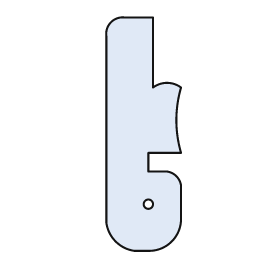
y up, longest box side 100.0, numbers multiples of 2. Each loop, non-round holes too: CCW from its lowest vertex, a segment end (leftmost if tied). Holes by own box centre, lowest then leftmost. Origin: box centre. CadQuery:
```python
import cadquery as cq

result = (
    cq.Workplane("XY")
    .moveTo(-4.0, -50.0)
    .lineTo(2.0, -50.0)
    .threePointArc((12.0, -46.0), (16.0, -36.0))
    .lineTo(16.0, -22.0)
    .threePointArc((14.0, -18.0), (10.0, -16.0))
    .lineTo(2.0, -16.0)
    .lineTo(2.0, -8.0)
    .lineTo(16.0, -8.0)
    .threePointArc((14.0, 6.0), (16.0, 20.0))
    .threePointArc((10.0, 22.0), (4.0, 20.0))
    .lineTo(4.0, 50.0)
    .lineTo(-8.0, 50.0)
    .threePointArc((-14.0, 48.0), (-16.0, 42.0))
    .lineTo(-16.0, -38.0)
    .threePointArc((-12.0, -46.0), (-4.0, -50.0))
    .close()
    .moveTo(2.0, -30.0)
    .circle(2.0)
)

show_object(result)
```